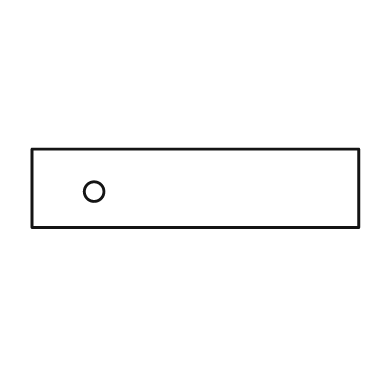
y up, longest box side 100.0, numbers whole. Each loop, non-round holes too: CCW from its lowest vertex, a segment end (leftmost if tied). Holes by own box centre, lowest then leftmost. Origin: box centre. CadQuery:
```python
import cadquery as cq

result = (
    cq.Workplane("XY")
    .moveTo(-50.0, -12.0)
    .lineTo(50.0, -12.0)
    .lineTo(50.0, 12.0)
    .lineTo(-50.0, 12.0)
    .close()
    .moveTo(-31.0, -1.0)
    .circle(3.0)
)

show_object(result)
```